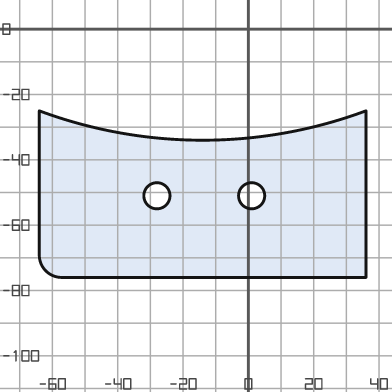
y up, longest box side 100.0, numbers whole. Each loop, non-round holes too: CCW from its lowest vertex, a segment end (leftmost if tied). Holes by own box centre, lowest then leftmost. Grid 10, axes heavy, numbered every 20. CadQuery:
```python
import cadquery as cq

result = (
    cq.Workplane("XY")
    .moveTo(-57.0, -76.0)
    .lineTo(36.0, -76.0)
    .lineTo(36.0, -25.0)
    .threePointArc((-14.0, -34.0), (-64.0, -25.0))
    .lineTo(-64.0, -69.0)
    .threePointArc((-62.0, -74.0), (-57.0, -76.0))
    .close()
    .moveTo(-28.0, -51.0)
    .circle(4.0)
    .moveTo(1.0, -51.0)
    .circle(4.0)
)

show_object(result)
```